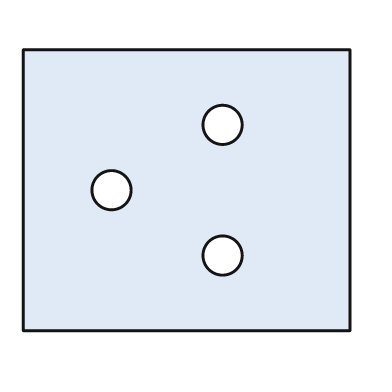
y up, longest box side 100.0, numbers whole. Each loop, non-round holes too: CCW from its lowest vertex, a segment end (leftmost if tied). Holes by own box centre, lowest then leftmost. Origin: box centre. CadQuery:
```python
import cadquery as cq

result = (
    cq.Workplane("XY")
    .moveTo(-50.0, -43.0)
    .lineTo(50.0, -43.0)
    .lineTo(50.0, 43.0)
    .lineTo(-50.0, 43.0)
    .close()
    .moveTo(11.0, -20.0)
    .circle(6.0)
    .moveTo(-23.0, 0.0)
    .circle(6.0)
    .moveTo(11.0, 20.0)
    .circle(6.0)
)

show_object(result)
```